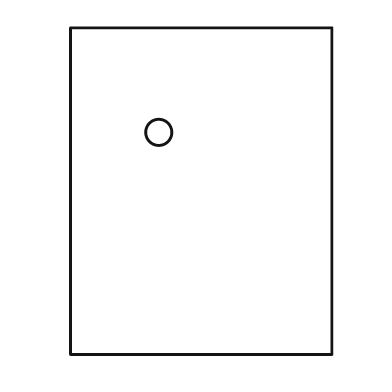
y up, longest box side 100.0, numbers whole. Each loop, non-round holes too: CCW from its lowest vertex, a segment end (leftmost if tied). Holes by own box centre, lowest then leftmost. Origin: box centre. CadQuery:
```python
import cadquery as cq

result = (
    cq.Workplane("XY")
    .moveTo(-40.0, -50.0)
    .lineTo(40.0, -50.0)
    .lineTo(40.0, 50.0)
    .lineTo(-40.0, 50.0)
    .close()
    .moveTo(-13.0, 18.0)
    .circle(4.0)
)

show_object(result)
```